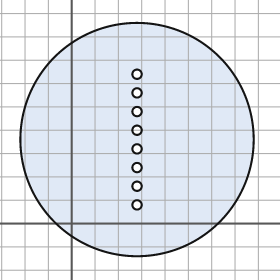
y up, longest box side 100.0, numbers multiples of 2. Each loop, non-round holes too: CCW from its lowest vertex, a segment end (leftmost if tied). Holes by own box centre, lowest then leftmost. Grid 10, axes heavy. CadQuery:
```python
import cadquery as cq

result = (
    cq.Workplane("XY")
    .moveTo(28.0, 36.0)
    .circle(50.0)
    .moveTo(28.0, 8.0)
    .circle(2.0)
    .moveTo(28.0, 16.0)
    .circle(2.0)
    .moveTo(28.0, 24.0)
    .circle(2.0)
    .moveTo(28.0, 32.0)
    .circle(2.0)
    .moveTo(28.0, 40.0)
    .circle(2.0)
    .moveTo(28.0, 48.0)
    .circle(2.0)
    .moveTo(28.0, 56.0)
    .circle(2.0)
    .moveTo(28.0, 64.0)
    .circle(2.0)
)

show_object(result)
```